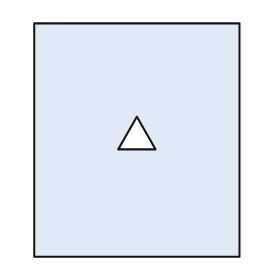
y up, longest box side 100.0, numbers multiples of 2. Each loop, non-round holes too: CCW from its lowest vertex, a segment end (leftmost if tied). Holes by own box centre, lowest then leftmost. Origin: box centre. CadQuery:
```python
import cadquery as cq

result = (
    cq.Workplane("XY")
    .moveTo(-44.0, -50.0)
    .lineTo(44.0, -50.0)
    .lineTo(44.0, 50.0)
    .lineTo(-44.0, 50.0)
    .close()
    .moveTo(-8.0, -4.0)
    .lineTo(8.0, -4.0)
    .lineTo(0.0, 10.0)
    .close()
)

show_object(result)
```